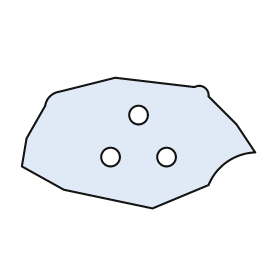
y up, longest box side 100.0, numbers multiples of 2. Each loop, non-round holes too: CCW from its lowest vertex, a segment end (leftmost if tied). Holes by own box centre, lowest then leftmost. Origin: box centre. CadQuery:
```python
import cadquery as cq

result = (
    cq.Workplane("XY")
    .moveTo(6.0, -28.0)
    .lineTo(30.0, -18.0)
    .threePointArc((38.0, -8.0), (50.0, -4.0))
    .lineTo(42.0, 8.0)
    .lineTo(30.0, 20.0)
    .threePointArc((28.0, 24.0), (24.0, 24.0))
    .lineTo(-10.0, 28.0)
    .lineTo(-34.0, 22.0)
    .threePointArc((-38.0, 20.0), (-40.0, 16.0))
    .lineTo(-48.0, 2.0)
    .lineTo(-50.0, -10.0)
    .lineTo(-32.0, -20.0)
    .close()
    .moveTo(-12.0, -6.0)
    .circle(4.0)
    .moveTo(12.0, -6.0)
    .circle(4.0)
    .moveTo(0.0, 12.0)
    .circle(4.0)
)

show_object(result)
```